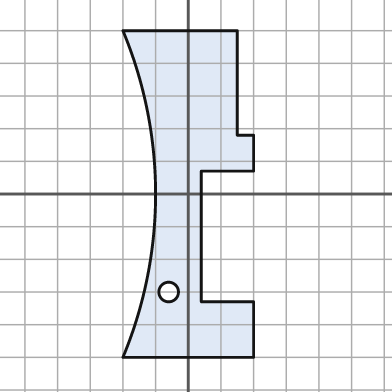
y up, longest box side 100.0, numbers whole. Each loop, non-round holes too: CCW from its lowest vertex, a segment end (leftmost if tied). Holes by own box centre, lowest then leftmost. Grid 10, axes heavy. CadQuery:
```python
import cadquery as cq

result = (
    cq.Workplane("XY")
    .moveTo(-20.0, -50.0)
    .lineTo(20.0, -50.0)
    .lineTo(20.0, -33.0)
    .lineTo(4.0, -33.0)
    .lineTo(4.0, 7.0)
    .lineTo(20.0, 7.0)
    .lineTo(20.0, 18.0)
    .lineTo(15.0, 18.0)
    .lineTo(15.0, 50.0)
    .lineTo(-20.0, 50.0)
    .threePointArc((-10.0, 0.0), (-20.0, -50.0))
    .close()
    .moveTo(-6.0, -30.0)
    .circle(3.0)
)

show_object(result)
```